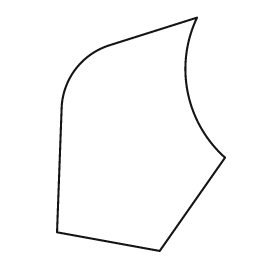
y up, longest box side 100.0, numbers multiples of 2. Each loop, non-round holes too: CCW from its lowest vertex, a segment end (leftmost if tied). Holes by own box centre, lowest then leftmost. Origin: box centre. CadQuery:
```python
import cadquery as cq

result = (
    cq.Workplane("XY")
    .moveTo(8.0, -50.0)
    .lineTo(36.0, -10.0)
    .threePointArc((20.0, 18.0), (24.0, 50.0))
    .lineTo(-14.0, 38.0)
    .threePointArc((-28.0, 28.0), (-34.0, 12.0))
    .lineTo(-36.0, -42.0)
    .close()
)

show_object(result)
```